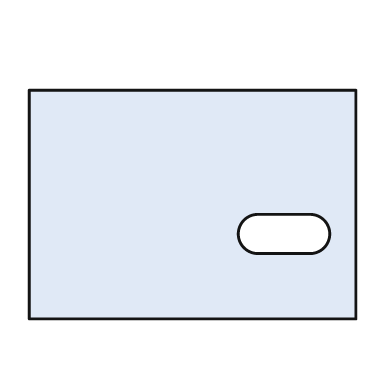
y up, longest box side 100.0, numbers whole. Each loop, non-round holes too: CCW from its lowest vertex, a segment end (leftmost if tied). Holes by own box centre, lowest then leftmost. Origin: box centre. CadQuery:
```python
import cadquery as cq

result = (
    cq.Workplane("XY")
    .moveTo(-50.0, -35.0)
    .lineTo(50.0, -35.0)
    .lineTo(50.0, 35.0)
    .lineTo(-50.0, 35.0)
    .close()
    .moveTo(20.0, -15.0)
    .lineTo(36.0, -15.0)
    .threePointArc((42.0, -9.0), (36.0, -3.0))
    .lineTo(20.0, -3.0)
    .threePointArc((14.0, -9.0), (20.0, -15.0))
    .close()
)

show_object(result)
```